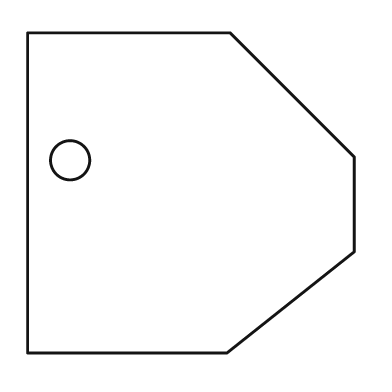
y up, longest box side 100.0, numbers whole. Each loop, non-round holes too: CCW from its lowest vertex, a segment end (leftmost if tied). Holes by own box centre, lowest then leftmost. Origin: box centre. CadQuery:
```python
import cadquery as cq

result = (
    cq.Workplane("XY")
    .moveTo(-50.0, -49.0)
    .lineTo(11.0, -49.0)
    .lineTo(50.0, -18.0)
    .lineTo(50.0, 11.0)
    .lineTo(12.0, 49.0)
    .lineTo(-50.0, 49.0)
    .close()
    .moveTo(-37.0, 10.0)
    .circle(6.0)
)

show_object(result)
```